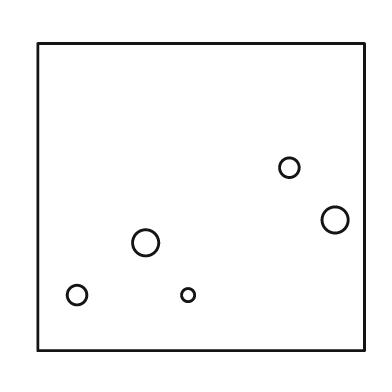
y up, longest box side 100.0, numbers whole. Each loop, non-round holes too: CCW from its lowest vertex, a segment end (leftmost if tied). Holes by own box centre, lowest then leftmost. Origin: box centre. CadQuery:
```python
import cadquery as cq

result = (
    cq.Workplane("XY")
    .moveTo(-50.0, -47.0)
    .lineTo(50.0, -47.0)
    .lineTo(50.0, 47.0)
    .lineTo(-50.0, 47.0)
    .close()
    .moveTo(-38.0, -30.0)
    .circle(3.0)
    .moveTo(-4.0, -30.0)
    .circle(2.0)
    .moveTo(-17.0, -14.0)
    .circle(4.0)
    .moveTo(41.0, -7.0)
    .circle(4.0)
    .moveTo(27.0, 9.0)
    .circle(3.0)
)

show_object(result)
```